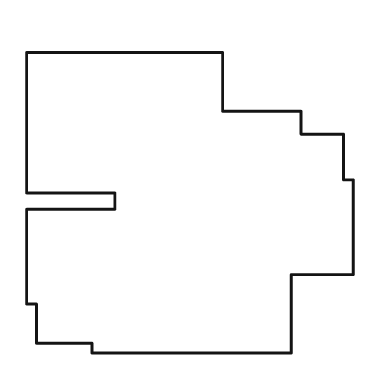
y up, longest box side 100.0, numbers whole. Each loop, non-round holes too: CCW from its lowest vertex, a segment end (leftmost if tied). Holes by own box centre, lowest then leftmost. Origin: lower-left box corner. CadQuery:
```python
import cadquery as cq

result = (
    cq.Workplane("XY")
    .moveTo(20.0, 0.0)
    .lineTo(81.0, 0.0)
    .lineTo(81.0, 24.0)
    .lineTo(100.0, 24.0)
    .lineTo(100.0, 53.0)
    .lineTo(97.0, 53.0)
    .lineTo(97.0, 67.0)
    .lineTo(84.0, 67.0)
    .lineTo(84.0, 74.0)
    .lineTo(60.0, 74.0)
    .lineTo(60.0, 92.0)
    .lineTo(0.0, 92.0)
    .lineTo(0.0, 49.0)
    .lineTo(27.0, 49.0)
    .lineTo(27.0, 44.0)
    .lineTo(0.0, 44.0)
    .lineTo(0.0, 15.0)
    .lineTo(3.0, 15.0)
    .lineTo(3.0, 3.0)
    .lineTo(20.0, 3.0)
    .close()
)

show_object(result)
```